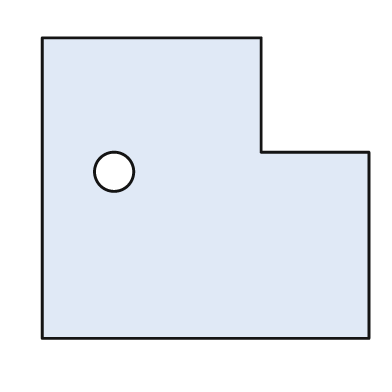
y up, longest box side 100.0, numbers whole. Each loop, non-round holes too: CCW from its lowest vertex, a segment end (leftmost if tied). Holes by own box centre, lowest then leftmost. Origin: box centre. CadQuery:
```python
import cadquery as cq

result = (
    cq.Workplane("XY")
    .moveTo(-50.0, -46.0)
    .lineTo(50.0, -46.0)
    .lineTo(50.0, 11.0)
    .lineTo(17.0, 11.0)
    .lineTo(17.0, 46.0)
    .lineTo(-50.0, 46.0)
    .close()
    .moveTo(-28.0, 5.0)
    .circle(6.0)
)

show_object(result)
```